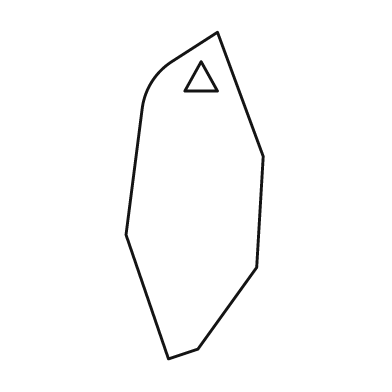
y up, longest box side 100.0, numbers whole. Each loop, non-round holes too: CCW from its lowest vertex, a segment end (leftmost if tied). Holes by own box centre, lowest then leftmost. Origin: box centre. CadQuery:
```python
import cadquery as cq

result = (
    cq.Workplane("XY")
    .moveTo(-8.0, -50.0)
    .lineTo(1.0, -47.0)
    .lineTo(19.0, -22.0)
    .lineTo(21.0, 12.0)
    .lineTo(7.0, 50.0)
    .lineTo(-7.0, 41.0)
    .threePointArc((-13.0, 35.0), (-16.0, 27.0))
    .lineTo(-21.0, -12.0)
    .close()
    .moveTo(-3.0, 32.0)
    .lineTo(7.0, 32.0)
    .lineTo(2.0, 41.0)
    .close()
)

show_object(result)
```